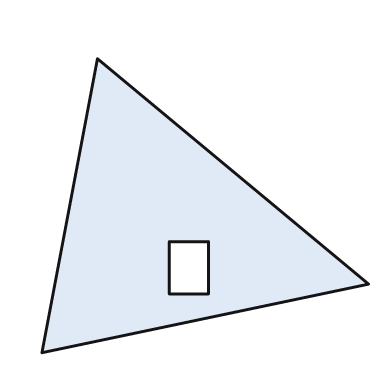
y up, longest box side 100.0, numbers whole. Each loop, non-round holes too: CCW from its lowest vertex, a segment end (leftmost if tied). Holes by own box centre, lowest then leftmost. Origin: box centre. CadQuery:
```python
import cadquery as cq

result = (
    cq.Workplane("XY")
    .moveTo(-50.0, -45.0)
    .lineTo(50.0, -24.0)
    .lineTo(-33.0, 45.0)
    .close()
    .moveTo(-11.0, -27.0)
    .lineTo(1.0, -27.0)
    .lineTo(1.0, -11.0)
    .lineTo(-11.0, -11.0)
    .close()
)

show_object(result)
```